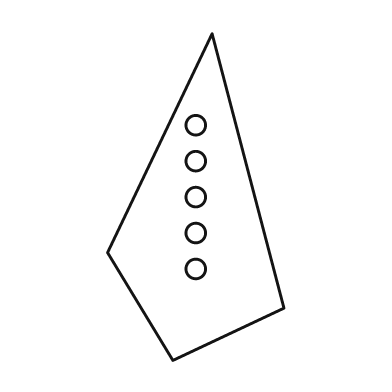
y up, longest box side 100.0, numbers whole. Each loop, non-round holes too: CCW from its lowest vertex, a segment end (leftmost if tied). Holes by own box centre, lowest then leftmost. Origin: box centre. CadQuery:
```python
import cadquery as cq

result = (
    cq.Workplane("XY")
    .moveTo(-7.0, -50.0)
    .lineTo(27.0, -34.0)
    .lineTo(5.0, 50.0)
    .lineTo(-27.0, -17.0)
    .close()
    .moveTo(0.0, -22.0)
    .circle(3.0)
    .moveTo(0.0, -11.0)
    .circle(3.0)
    .moveTo(0.0, 0.0)
    .circle(3.0)
    .moveTo(0.0, 11.0)
    .circle(3.0)
    .moveTo(0.0, 22.0)
    .circle(3.0)
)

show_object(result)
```